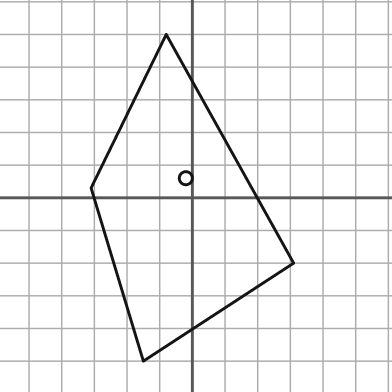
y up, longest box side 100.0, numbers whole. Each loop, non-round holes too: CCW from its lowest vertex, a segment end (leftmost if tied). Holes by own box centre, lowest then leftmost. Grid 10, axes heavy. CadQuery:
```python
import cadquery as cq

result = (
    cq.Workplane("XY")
    .moveTo(-15.0, -50.0)
    .lineTo(31.0, -20.0)
    .lineTo(-8.0, 50.0)
    .lineTo(-31.0, 3.0)
    .close()
    .moveTo(-2.0, 6.0)
    .circle(2.0)
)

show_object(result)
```